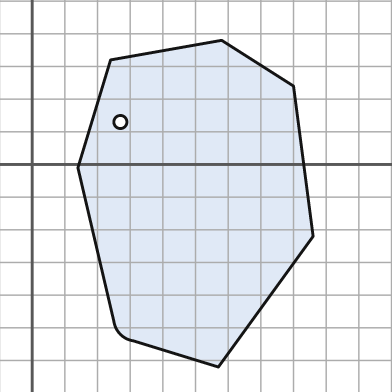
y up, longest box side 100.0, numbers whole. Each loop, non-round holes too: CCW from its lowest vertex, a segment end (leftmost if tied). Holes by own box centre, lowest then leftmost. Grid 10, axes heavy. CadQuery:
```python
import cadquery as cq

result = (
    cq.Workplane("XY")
    .moveTo(57.0, -62.0)
    .lineTo(86.0, -22.0)
    .lineTo(80.0, 24.0)
    .lineTo(58.0, 38.0)
    .lineTo(24.0, 32.0)
    .lineTo(14.0, -1.0)
    .lineTo(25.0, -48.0)
    .threePointArc((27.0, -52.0), (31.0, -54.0))
    .close()
    .moveTo(27.0, 13.0)
    .circle(2.0)
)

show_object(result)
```